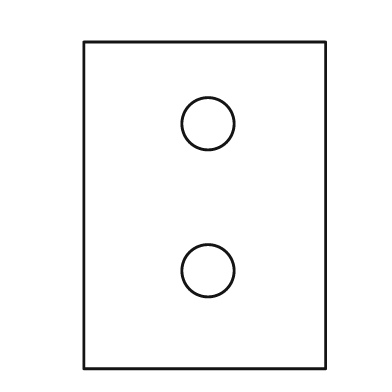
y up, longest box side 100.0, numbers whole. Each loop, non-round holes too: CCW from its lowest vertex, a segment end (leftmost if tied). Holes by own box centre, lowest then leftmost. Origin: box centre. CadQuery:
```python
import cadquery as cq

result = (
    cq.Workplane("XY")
    .moveTo(-37.0, -50.0)
    .lineTo(37.0, -50.0)
    .lineTo(37.0, 50.0)
    .lineTo(-37.0, 50.0)
    .close()
    .moveTo(1.0, -20.0)
    .circle(8.0)
    .moveTo(1.0, 25.0)
    .circle(8.0)
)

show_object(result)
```